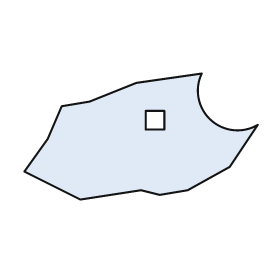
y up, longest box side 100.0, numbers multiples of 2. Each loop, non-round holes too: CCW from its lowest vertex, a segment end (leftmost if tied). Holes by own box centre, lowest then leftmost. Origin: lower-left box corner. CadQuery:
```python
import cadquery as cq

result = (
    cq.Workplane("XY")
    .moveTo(24.0, 0.0)
    .lineTo(50.0, 4.0)
    .lineTo(58.0, 2.0)
    .lineTo(70.0, 4.0)
    .lineTo(88.0, 14.0)
    .lineTo(100.0, 32.0)
    .threePointArc((80.0, 34.0), (76.0, 54.0))
    .lineTo(48.0, 50.0)
    .lineTo(28.0, 42.0)
    .lineTo(16.0, 40.0)
    .lineTo(10.0, 26.0)
    .lineTo(0.0, 12.0)
    .close()
    .moveTo(52.0, 30.0)
    .lineTo(60.0, 30.0)
    .lineTo(60.0, 38.0)
    .lineTo(52.0, 38.0)
    .close()
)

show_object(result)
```